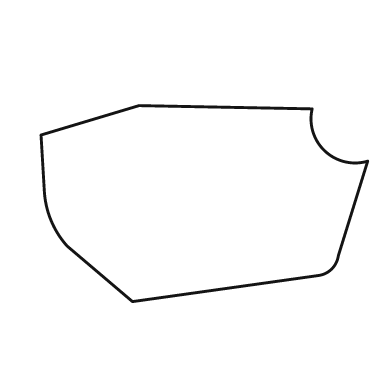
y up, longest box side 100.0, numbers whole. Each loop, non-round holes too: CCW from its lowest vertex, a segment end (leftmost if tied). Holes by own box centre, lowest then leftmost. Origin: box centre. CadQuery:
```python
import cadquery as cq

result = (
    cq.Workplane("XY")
    .moveTo(-22.0, -30.0)
    .lineTo(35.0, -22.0)
    .threePointArc((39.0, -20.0), (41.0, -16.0))
    .lineTo(50.0, 13.0)
    .threePointArc((37.0, 16.0), (33.0, 29.0))
    .lineTo(-20.0, 30.0)
    .lineTo(-50.0, 21.0)
    .lineTo(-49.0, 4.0)
    .threePointArc((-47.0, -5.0), (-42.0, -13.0))
    .close()
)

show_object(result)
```